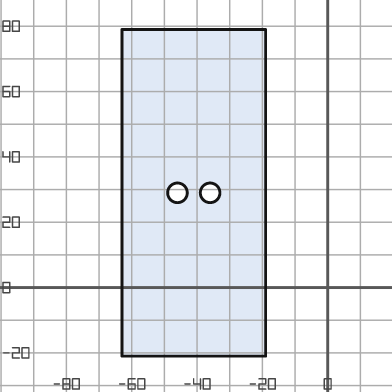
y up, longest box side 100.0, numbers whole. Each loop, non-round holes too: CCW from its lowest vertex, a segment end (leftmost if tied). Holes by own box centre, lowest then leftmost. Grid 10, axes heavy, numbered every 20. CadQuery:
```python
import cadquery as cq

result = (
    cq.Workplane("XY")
    .moveTo(-63.0, -21.0)
    .lineTo(-19.0, -21.0)
    .lineTo(-19.0, 79.0)
    .lineTo(-63.0, 79.0)
    .close()
    .moveTo(-46.0, 29.0)
    .circle(3.0)
    .moveTo(-36.0, 29.0)
    .circle(3.0)
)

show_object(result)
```